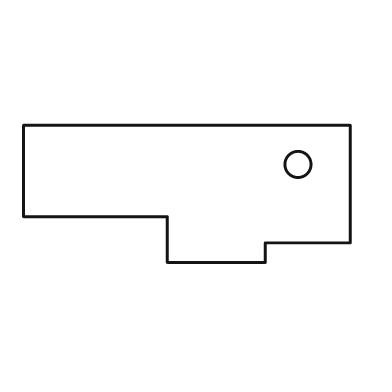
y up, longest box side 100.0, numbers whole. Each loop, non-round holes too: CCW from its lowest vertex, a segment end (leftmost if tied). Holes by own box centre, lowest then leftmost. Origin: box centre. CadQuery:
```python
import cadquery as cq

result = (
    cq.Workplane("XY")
    .moveTo(-6.0, -21.0)
    .lineTo(24.0, -21.0)
    .lineTo(24.0, -15.0)
    .lineTo(50.0, -15.0)
    .lineTo(50.0, 21.0)
    .lineTo(-50.0, 21.0)
    .lineTo(-50.0, -7.0)
    .lineTo(-6.0, -7.0)
    .close()
    .moveTo(34.0, 9.0)
    .circle(4.0)
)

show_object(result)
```